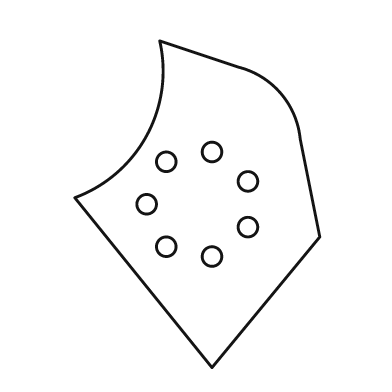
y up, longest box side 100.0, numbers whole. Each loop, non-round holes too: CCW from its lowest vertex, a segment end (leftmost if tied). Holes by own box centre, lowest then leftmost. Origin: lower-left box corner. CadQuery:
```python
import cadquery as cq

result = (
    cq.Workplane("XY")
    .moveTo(42.0, 0.0)
    .lineTo(75.0, 40.0)
    .lineTo(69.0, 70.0)
    .threePointArc((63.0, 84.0), (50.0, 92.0))
    .lineTo(26.0, 100.0)
    .threePointArc((22.0, 71.0), (0.0, 52.0))
    .close()
    .moveTo(42.0, 34.0)
    .circle(3.0)
    .moveTo(28.0, 37.0)
    .circle(3.0)
    .moveTo(53.0, 43.0)
    .circle(3.0)
    .moveTo(22.0, 50.0)
    .circle(3.0)
    .moveTo(53.0, 57.0)
    .circle(3.0)
    .moveTo(28.0, 63.0)
    .circle(3.0)
    .moveTo(42.0, 66.0)
    .circle(3.0)
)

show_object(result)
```